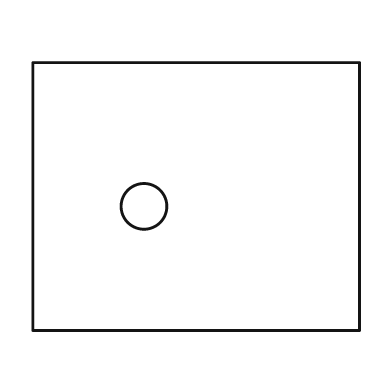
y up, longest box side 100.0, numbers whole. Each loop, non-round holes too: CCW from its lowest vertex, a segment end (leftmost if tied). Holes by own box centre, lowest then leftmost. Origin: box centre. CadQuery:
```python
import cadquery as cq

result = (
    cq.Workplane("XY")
    .moveTo(-50.0, -41.0)
    .lineTo(50.0, -41.0)
    .lineTo(50.0, 41.0)
    .lineTo(-50.0, 41.0)
    .close()
    .moveTo(-16.0, -3.0)
    .circle(7.0)
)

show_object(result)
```